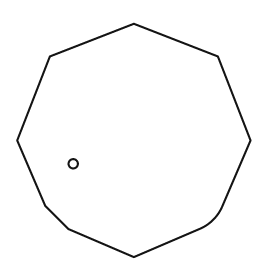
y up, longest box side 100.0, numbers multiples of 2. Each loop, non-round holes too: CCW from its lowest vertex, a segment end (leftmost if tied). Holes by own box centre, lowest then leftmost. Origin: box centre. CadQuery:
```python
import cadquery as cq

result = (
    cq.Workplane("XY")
    .moveTo(0.0, -50.0)
    .lineTo(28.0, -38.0)
    .threePointArc((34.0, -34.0), (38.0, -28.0))
    .lineTo(50.0, 0.0)
    .lineTo(36.0, 36.0)
    .lineTo(0.0, 50.0)
    .lineTo(-36.0, 36.0)
    .lineTo(-50.0, 0.0)
    .lineTo(-38.0, -28.0)
    .lineTo(-28.0, -38.0)
    .close()
    .moveTo(-26.0, -10.0)
    .circle(2.0)
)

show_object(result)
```